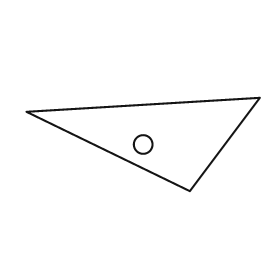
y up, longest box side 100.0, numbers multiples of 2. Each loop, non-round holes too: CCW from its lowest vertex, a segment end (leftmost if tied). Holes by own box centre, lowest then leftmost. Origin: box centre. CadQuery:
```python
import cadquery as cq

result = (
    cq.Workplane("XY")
    .moveTo(20.0, -20.0)
    .lineTo(50.0, 20.0)
    .lineTo(-50.0, 14.0)
    .close()
    .moveTo(0.0, 0.0)
    .circle(4.0)
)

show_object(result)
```